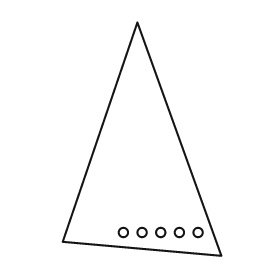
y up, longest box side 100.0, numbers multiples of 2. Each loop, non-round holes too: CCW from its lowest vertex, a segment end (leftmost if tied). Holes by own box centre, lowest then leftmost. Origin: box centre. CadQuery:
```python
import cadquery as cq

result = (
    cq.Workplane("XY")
    .moveTo(34.0, -50.0)
    .lineTo(-2.0, 50.0)
    .lineTo(-34.0, -44.0)
    .close()
    .moveTo(-8.0, -40.0)
    .circle(2.0)
    .moveTo(0.0, -40.0)
    .circle(2.0)
    .moveTo(8.0, -40.0)
    .circle(2.0)
    .moveTo(16.0, -40.0)
    .circle(2.0)
    .moveTo(24.0, -40.0)
    .circle(2.0)
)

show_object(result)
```